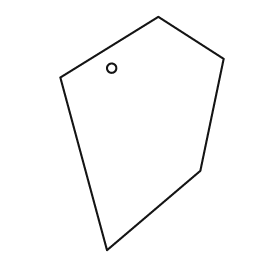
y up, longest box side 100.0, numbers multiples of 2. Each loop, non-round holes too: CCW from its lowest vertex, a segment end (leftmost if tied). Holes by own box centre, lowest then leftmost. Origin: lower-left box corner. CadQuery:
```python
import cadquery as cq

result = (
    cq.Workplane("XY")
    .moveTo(20.0, 0.0)
    .lineTo(60.0, 34.0)
    .lineTo(70.0, 82.0)
    .lineTo(42.0, 100.0)
    .lineTo(0.0, 74.0)
    .close()
    .moveTo(22.0, 78.0)
    .circle(2.0)
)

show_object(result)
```